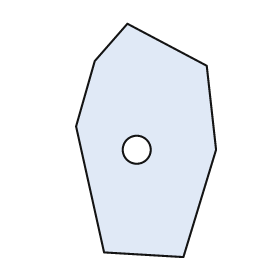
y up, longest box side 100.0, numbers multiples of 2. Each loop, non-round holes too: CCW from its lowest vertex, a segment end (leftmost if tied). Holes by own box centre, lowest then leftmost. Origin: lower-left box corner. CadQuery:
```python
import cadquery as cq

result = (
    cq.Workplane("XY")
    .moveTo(46.0, 0.0)
    .lineTo(60.0, 46.0)
    .lineTo(56.0, 82.0)
    .lineTo(22.0, 100.0)
    .lineTo(8.0, 84.0)
    .lineTo(0.0, 56.0)
    .lineTo(12.0, 2.0)
    .close()
    .moveTo(26.0, 46.0)
    .circle(6.0)
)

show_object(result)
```